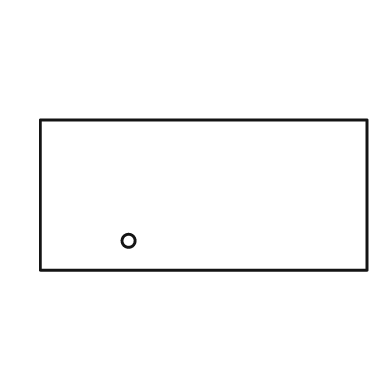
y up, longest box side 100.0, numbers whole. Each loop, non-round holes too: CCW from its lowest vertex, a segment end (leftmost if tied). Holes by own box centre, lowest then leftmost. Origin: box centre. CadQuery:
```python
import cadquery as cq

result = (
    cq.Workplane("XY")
    .moveTo(-50.0, -23.0)
    .lineTo(50.0, -23.0)
    .lineTo(50.0, 23.0)
    .lineTo(-50.0, 23.0)
    .close()
    .moveTo(-23.0, -14.0)
    .circle(2.0)
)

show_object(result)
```